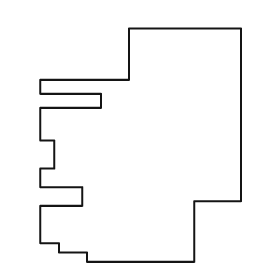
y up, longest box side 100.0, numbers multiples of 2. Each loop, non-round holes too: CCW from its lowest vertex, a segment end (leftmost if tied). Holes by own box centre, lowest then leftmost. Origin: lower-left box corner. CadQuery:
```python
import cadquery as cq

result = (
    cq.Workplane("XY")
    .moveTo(20.0, 0.0)
    .lineTo(66.0, 0.0)
    .lineTo(66.0, 26.0)
    .lineTo(86.0, 26.0)
    .lineTo(86.0, 100.0)
    .lineTo(38.0, 100.0)
    .lineTo(38.0, 78.0)
    .lineTo(0.0, 78.0)
    .lineTo(0.0, 72.0)
    .lineTo(26.0, 72.0)
    .lineTo(26.0, 66.0)
    .lineTo(0.0, 66.0)
    .lineTo(0.0, 52.0)
    .lineTo(6.0, 52.0)
    .lineTo(6.0, 40.0)
    .lineTo(0.0, 40.0)
    .lineTo(0.0, 32.0)
    .lineTo(18.0, 32.0)
    .lineTo(18.0, 24.0)
    .lineTo(0.0, 24.0)
    .lineTo(0.0, 8.0)
    .lineTo(8.0, 8.0)
    .lineTo(8.0, 4.0)
    .lineTo(20.0, 4.0)
    .close()
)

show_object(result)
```